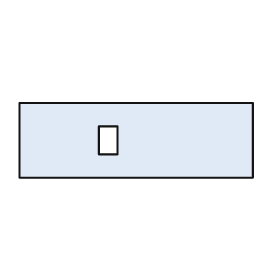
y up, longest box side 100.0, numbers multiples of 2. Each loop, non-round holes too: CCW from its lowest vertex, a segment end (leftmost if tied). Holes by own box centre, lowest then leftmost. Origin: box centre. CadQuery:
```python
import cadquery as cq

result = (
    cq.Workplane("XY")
    .moveTo(-50.0, -16.0)
    .lineTo(50.0, -16.0)
    .lineTo(50.0, 16.0)
    .lineTo(-50.0, 16.0)
    .close()
    .moveTo(-16.0, -6.0)
    .lineTo(-8.0, -6.0)
    .lineTo(-8.0, 6.0)
    .lineTo(-16.0, 6.0)
    .close()
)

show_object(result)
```